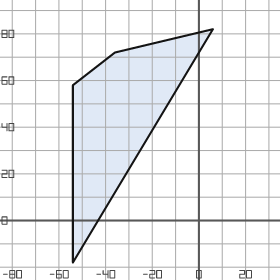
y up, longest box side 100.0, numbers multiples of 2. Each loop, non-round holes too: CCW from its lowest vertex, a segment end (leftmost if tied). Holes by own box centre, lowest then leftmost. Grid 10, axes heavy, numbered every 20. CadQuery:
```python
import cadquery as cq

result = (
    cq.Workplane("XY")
    .moveTo(-54.0, -18.0)
    .lineTo(6.0, 82.0)
    .lineTo(-36.0, 72.0)
    .lineTo(-54.0, 58.0)
    .close()
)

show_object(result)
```